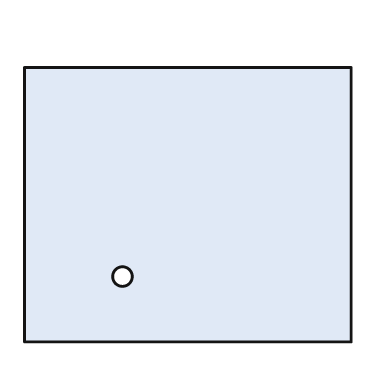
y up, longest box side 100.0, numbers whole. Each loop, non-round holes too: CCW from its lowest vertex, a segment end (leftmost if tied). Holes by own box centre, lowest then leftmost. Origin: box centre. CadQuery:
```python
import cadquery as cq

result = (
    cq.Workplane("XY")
    .moveTo(-50.0, -42.0)
    .lineTo(50.0, -42.0)
    .lineTo(50.0, 42.0)
    .lineTo(-50.0, 42.0)
    .close()
    .moveTo(-20.0, -22.0)
    .circle(3.0)
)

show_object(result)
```